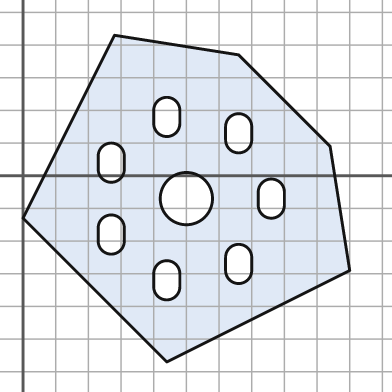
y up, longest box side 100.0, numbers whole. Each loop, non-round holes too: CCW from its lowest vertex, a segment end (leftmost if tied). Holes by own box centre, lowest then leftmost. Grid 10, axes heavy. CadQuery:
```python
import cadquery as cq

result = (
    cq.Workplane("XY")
    .moveTo(44.0, -57.0)
    .lineTo(100.0, -29.0)
    .lineTo(94.0, 9.0)
    .lineTo(66.0, 37.0)
    .lineTo(28.0, 43.0)
    .lineTo(0.0, -13.0)
    .close()
    .moveTo(40.0, -34.0)
    .threePointArc((44.0, -38.0), (48.0, -34.0))
    .lineTo(48.0, -30.0)
    .threePointArc((44.0, -26.0), (40.0, -30.0))
    .close()
    .moveTo(62.0, -29.0)
    .threePointArc((66.0, -33.0), (70.0, -29.0))
    .lineTo(70.0, -25.0)
    .threePointArc((66.0, -21.0), (62.0, -25.0))
    .close()
    .moveTo(23.0, -20.0)
    .threePointArc((27.0, -24.0), (31.0, -20.0))
    .lineTo(31.0, -16.0)
    .threePointArc((27.0, -12.0), (23.0, -16.0))
    .close()
    .moveTo(50.0, -7.0)
    .circle(8.0)
    .moveTo(72.0, -9.0)
    .threePointArc((76.0, -13.0), (80.0, -9.0))
    .lineTo(80.0, -5.0)
    .threePointArc((76.0, -1.0), (72.0, -5.0))
    .close()
    .moveTo(23.0, 2.0)
    .threePointArc((27.0, -2.0), (31.0, 2.0))
    .lineTo(31.0, 6.0)
    .threePointArc((27.0, 10.0), (23.0, 6.0))
    .close()
    .moveTo(62.0, 11.0)
    .threePointArc((66.0, 7.0), (70.0, 11.0))
    .lineTo(70.0, 15.0)
    .threePointArc((66.0, 19.0), (62.0, 15.0))
    .close()
    .moveTo(40.0, 16.0)
    .threePointArc((44.0, 12.0), (48.0, 16.0))
    .lineTo(48.0, 20.0)
    .threePointArc((44.0, 24.0), (40.0, 20.0))
    .close()
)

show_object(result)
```